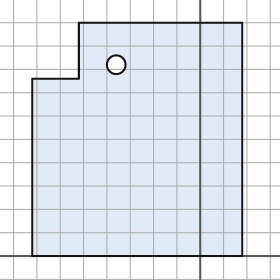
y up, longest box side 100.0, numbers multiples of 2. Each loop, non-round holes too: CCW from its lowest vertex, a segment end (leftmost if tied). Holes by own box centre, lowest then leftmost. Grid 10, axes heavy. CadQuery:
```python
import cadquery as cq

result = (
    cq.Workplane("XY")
    .moveTo(-72.0, 0.0)
    .lineTo(18.0, 0.0)
    .lineTo(18.0, 100.0)
    .lineTo(-52.0, 100.0)
    .lineTo(-52.0, 76.0)
    .lineTo(-72.0, 76.0)
    .close()
    .moveTo(-36.0, 82.0)
    .circle(4.0)
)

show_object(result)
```